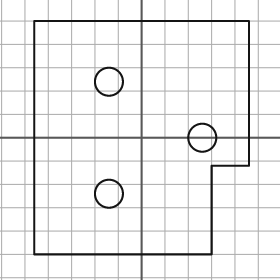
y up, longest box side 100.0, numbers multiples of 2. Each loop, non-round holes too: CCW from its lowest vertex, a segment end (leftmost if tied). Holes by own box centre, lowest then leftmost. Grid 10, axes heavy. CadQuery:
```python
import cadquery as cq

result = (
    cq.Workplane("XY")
    .moveTo(-46.0, -50.0)
    .lineTo(30.0, -50.0)
    .lineTo(30.0, -12.0)
    .lineTo(46.0, -12.0)
    .lineTo(46.0, 50.0)
    .lineTo(-46.0, 50.0)
    .close()
    .moveTo(-14.0, -24.0)
    .circle(6.0)
    .moveTo(26.0, 0.0)
    .circle(6.0)
    .moveTo(-14.0, 24.0)
    .circle(6.0)
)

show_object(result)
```